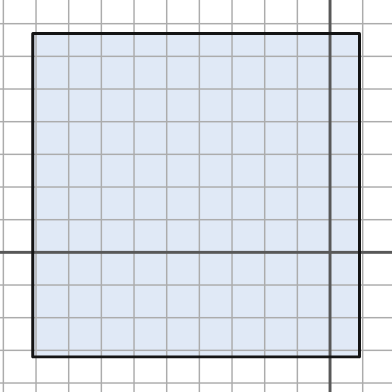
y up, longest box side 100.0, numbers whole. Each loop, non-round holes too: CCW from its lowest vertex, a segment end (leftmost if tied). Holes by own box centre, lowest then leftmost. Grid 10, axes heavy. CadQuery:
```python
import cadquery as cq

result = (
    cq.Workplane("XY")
    .moveTo(-91.0, -32.0)
    .lineTo(9.0, -32.0)
    .lineTo(9.0, 67.0)
    .lineTo(-91.0, 67.0)
    .close()
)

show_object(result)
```